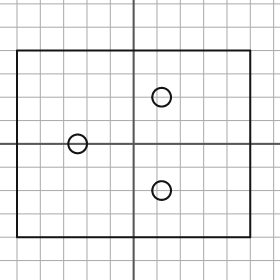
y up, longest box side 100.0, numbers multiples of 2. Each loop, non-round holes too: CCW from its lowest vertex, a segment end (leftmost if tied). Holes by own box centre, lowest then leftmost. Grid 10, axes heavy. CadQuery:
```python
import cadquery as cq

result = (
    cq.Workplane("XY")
    .moveTo(-50.0, -40.0)
    .lineTo(50.0, -40.0)
    .lineTo(50.0, 40.0)
    .lineTo(-50.0, 40.0)
    .close()
    .moveTo(12.0, -20.0)
    .circle(4.0)
    .moveTo(-24.0, 0.0)
    .circle(4.0)
    .moveTo(12.0, 20.0)
    .circle(4.0)
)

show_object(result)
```